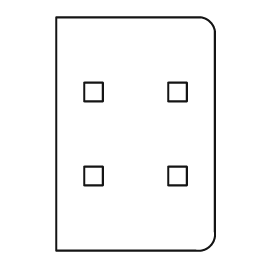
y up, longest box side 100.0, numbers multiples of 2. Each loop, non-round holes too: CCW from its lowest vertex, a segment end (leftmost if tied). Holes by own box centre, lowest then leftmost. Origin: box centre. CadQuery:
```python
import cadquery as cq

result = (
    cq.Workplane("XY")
    .moveTo(-34.0, -50.0)
    .lineTo(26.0, -50.0)
    .threePointArc((32.0, -48.0), (34.0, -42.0))
    .lineTo(34.0, 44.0)
    .threePointArc((32.0, 48.0), (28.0, 50.0))
    .lineTo(-34.0, 50.0)
    .close()
    .moveTo(-22.0, -22.0)
    .lineTo(-14.0, -22.0)
    .lineTo(-14.0, -14.0)
    .lineTo(-22.0, -14.0)
    .close()
    .moveTo(14.0, -22.0)
    .lineTo(22.0, -22.0)
    .lineTo(22.0, -14.0)
    .lineTo(14.0, -14.0)
    .close()
    .moveTo(-22.0, 14.0)
    .lineTo(-14.0, 14.0)
    .lineTo(-14.0, 22.0)
    .lineTo(-22.0, 22.0)
    .close()
    .moveTo(14.0, 14.0)
    .lineTo(22.0, 14.0)
    .lineTo(22.0, 22.0)
    .lineTo(14.0, 22.0)
    .close()
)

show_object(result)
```